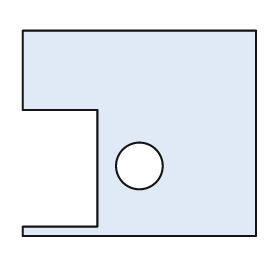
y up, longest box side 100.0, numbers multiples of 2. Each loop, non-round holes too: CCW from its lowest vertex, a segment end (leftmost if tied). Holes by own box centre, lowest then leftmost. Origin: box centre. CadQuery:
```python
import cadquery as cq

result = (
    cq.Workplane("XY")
    .moveTo(-50.0, -44.0)
    .lineTo(50.0, -44.0)
    .lineTo(50.0, 44.0)
    .lineTo(-50.0, 44.0)
    .lineTo(-50.0, 10.0)
    .lineTo(-18.0, 10.0)
    .lineTo(-18.0, -40.0)
    .lineTo(-50.0, -40.0)
    .close()
    .moveTo(0.0, -14.0)
    .circle(10.0)
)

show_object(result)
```